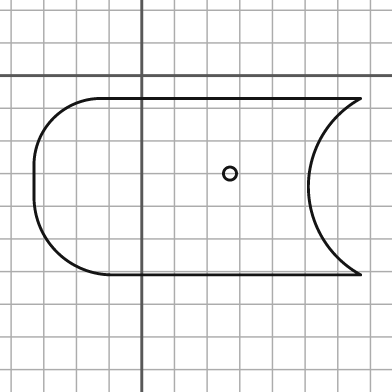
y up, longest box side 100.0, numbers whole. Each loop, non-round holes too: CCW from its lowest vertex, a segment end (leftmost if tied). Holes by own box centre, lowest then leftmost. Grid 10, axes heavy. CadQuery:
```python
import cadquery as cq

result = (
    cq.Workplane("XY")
    .moveTo(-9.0, -61.0)
    .lineTo(67.0, -61.0)
    .threePointArc((51.0, -34.0), (67.0, -7.0))
    .lineTo(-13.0, -7.0)
    .threePointArc((-27.0, -13.0), (-33.0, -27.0))
    .lineTo(-33.0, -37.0)
    .threePointArc((-26.0, -54.0), (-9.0, -61.0))
    .close()
    .moveTo(27.0, -30.0)
    .circle(2.0)
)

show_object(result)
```